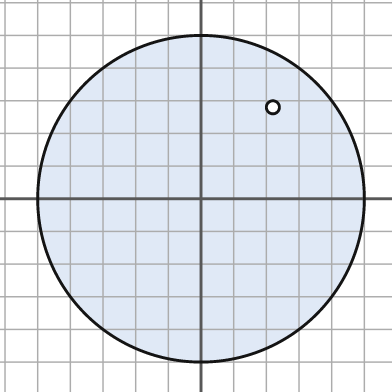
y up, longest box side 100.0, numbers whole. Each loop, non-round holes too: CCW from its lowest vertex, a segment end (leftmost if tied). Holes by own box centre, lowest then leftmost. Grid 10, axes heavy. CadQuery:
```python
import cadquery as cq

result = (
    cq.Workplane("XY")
    .moveTo(0.0, 0.0)
    .circle(50.0)
    .moveTo(22.0, 28.0)
    .circle(2.0)
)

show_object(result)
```